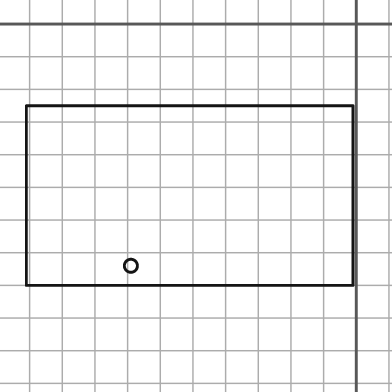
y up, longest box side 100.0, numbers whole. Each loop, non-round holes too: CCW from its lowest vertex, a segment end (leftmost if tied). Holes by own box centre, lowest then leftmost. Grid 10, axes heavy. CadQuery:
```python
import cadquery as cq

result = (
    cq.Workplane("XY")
    .moveTo(-101.0, -80.0)
    .lineTo(-1.0, -80.0)
    .lineTo(-1.0, -25.0)
    .lineTo(-101.0, -25.0)
    .close()
    .moveTo(-69.0, -74.0)
    .circle(2.0)
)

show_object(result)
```